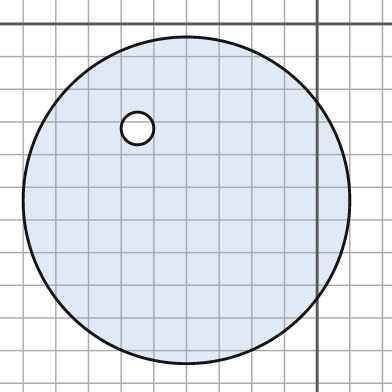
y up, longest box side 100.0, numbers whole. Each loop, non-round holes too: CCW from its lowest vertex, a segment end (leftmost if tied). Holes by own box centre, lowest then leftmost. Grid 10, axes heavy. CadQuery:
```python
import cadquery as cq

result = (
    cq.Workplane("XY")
    .moveTo(-40.0, -54.0)
    .circle(50.0)
    .moveTo(-55.0, -32.0)
    .circle(5.0)
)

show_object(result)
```